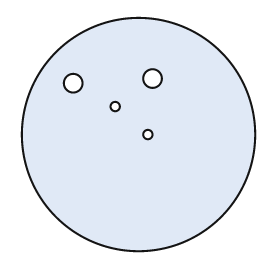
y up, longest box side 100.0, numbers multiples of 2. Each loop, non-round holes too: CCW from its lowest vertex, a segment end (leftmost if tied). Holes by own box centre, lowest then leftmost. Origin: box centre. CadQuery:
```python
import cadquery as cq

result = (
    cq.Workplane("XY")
    .moveTo(0.0, 0.0)
    .circle(50.0)
    .moveTo(4.0, 0.0)
    .circle(2.0)
    .moveTo(-10.0, 12.0)
    .circle(2.0)
    .moveTo(-28.0, 22.0)
    .circle(4.0)
    .moveTo(6.0, 24.0)
    .circle(4.0)
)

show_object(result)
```